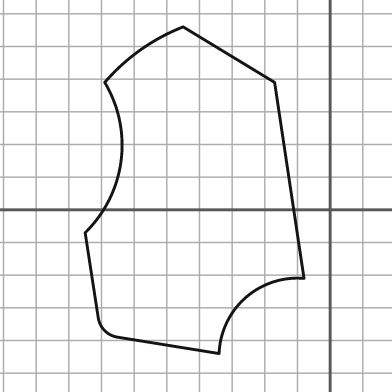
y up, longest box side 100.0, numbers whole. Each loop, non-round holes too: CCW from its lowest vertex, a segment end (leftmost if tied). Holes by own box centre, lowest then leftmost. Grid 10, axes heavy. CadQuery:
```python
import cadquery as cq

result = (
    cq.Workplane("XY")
    .moveTo(-34.0, -44.0)
    .threePointArc((-26.0, -27.0), (-8.0, -21.0))
    .lineTo(-17.0, 39.0)
    .lineTo(-45.0, 56.0)
    .threePointArc((-58.0, 49.0), (-69.0, 39.0))
    .threePointArc((-64.0, 15.0), (-75.0, -7.0))
    .lineTo(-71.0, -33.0)
    .threePointArc((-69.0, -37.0), (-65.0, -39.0))
    .close()
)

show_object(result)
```